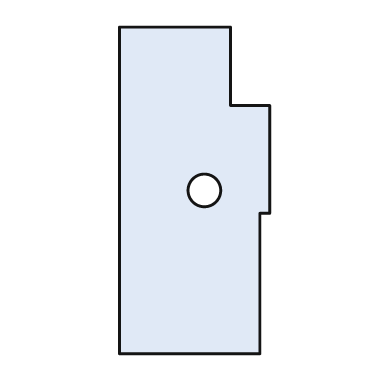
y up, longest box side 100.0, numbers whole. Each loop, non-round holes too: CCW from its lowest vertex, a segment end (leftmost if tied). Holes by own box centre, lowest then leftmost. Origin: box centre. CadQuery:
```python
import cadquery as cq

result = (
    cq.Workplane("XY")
    .moveTo(-23.0, -50.0)
    .lineTo(20.0, -50.0)
    .lineTo(20.0, -7.0)
    .lineTo(23.0, -7.0)
    .lineTo(23.0, 26.0)
    .lineTo(11.0, 26.0)
    .lineTo(11.0, 50.0)
    .lineTo(-23.0, 50.0)
    .close()
    .moveTo(3.0, 0.0)
    .circle(5.0)
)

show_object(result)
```